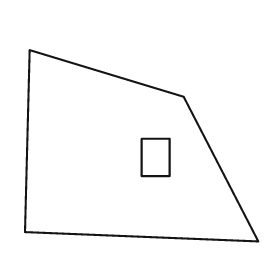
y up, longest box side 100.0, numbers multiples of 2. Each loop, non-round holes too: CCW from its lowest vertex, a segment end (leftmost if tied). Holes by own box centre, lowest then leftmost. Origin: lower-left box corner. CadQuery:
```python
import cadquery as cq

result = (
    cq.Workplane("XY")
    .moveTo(100.0, 0.0)
    .lineTo(68.0, 62.0)
    .lineTo(2.0, 82.0)
    .lineTo(0.0, 4.0)
    .close()
    .moveTo(50.0, 28.0)
    .lineTo(62.0, 28.0)
    .lineTo(62.0, 44.0)
    .lineTo(50.0, 44.0)
    .close()
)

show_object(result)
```